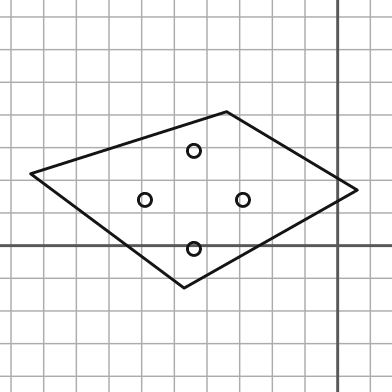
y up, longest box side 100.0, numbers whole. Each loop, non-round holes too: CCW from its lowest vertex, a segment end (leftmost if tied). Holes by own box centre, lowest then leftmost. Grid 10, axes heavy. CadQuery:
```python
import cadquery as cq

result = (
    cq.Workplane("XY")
    .moveTo(-47.0, -13.0)
    .lineTo(6.0, 17.0)
    .lineTo(-34.0, 41.0)
    .lineTo(-94.0, 22.0)
    .close()
    .moveTo(-44.0, -1.0)
    .circle(2.0)
    .moveTo(-59.0, 14.0)
    .circle(2.0)
    .moveTo(-29.0, 14.0)
    .circle(2.0)
    .moveTo(-44.0, 29.0)
    .circle(2.0)
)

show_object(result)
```